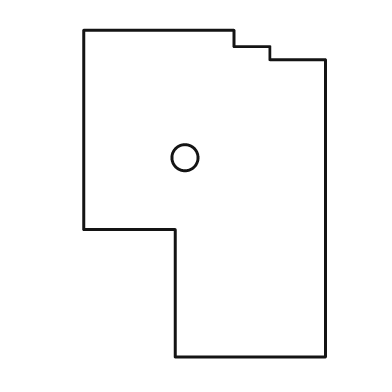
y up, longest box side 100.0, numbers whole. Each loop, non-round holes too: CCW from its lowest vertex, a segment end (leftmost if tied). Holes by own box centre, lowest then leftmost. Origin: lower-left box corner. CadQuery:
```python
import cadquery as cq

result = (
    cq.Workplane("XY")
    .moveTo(28.0, 0.0)
    .lineTo(74.0, 0.0)
    .lineTo(74.0, 91.0)
    .lineTo(57.0, 91.0)
    .lineTo(57.0, 95.0)
    .lineTo(46.0, 95.0)
    .lineTo(46.0, 100.0)
    .lineTo(0.0, 100.0)
    .lineTo(0.0, 39.0)
    .lineTo(28.0, 39.0)
    .close()
    .moveTo(31.0, 61.0)
    .circle(4.0)
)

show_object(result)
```